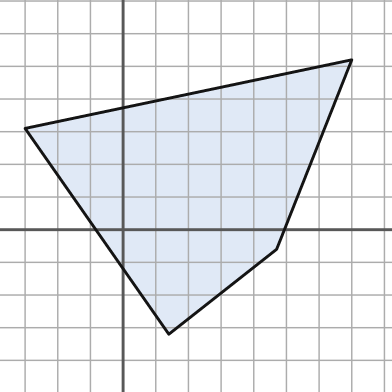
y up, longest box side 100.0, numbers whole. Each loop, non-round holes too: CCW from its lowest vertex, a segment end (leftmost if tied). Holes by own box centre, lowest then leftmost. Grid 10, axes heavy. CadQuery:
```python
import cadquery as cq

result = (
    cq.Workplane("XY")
    .moveTo(14.0, -32.0)
    .lineTo(47.0, -6.0)
    .lineTo(70.0, 52.0)
    .lineTo(-30.0, 31.0)
    .close()
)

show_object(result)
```